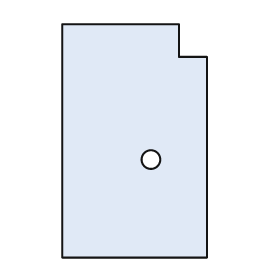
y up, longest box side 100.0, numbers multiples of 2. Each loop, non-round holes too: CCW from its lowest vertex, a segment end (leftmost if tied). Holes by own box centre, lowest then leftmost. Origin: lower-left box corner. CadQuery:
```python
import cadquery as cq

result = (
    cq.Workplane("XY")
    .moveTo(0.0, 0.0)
    .lineTo(62.0, 0.0)
    .lineTo(62.0, 86.0)
    .lineTo(50.0, 86.0)
    .lineTo(50.0, 100.0)
    .lineTo(0.0, 100.0)
    .close()
    .moveTo(38.0, 42.0)
    .circle(4.0)
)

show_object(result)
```